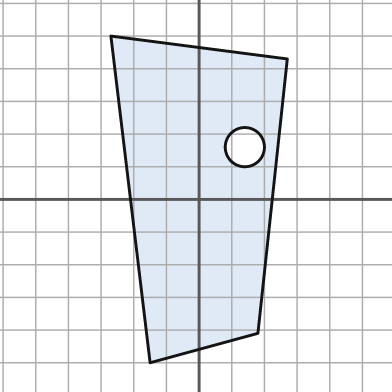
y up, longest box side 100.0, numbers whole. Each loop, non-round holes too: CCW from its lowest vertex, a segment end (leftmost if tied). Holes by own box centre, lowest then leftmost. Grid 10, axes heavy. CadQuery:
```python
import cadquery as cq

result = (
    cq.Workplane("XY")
    .moveTo(-15.0, -50.0)
    .lineTo(18.0, -41.0)
    .lineTo(27.0, 43.0)
    .lineTo(-27.0, 50.0)
    .close()
    .moveTo(14.0, 16.0)
    .circle(6.0)
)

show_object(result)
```